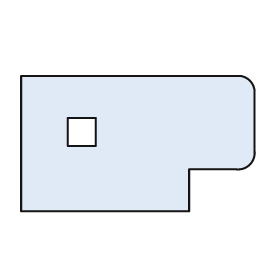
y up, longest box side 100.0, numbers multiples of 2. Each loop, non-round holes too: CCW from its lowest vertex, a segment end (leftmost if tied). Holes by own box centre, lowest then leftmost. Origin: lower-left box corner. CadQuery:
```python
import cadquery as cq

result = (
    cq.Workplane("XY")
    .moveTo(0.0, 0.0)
    .lineTo(72.0, 0.0)
    .lineTo(72.0, 18.0)
    .lineTo(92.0, 18.0)
    .threePointArc((98.0, 20.0), (100.0, 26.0))
    .lineTo(100.0, 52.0)
    .threePointArc((98.0, 56.0), (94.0, 58.0))
    .lineTo(0.0, 58.0)
    .close()
    .moveTo(20.0, 28.0)
    .lineTo(32.0, 28.0)
    .lineTo(32.0, 40.0)
    .lineTo(20.0, 40.0)
    .close()
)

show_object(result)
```